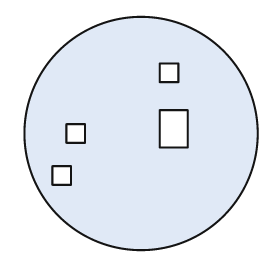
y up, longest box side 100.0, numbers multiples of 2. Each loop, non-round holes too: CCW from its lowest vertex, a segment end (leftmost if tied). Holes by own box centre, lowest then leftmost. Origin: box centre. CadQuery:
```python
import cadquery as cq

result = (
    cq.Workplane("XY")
    .moveTo(0.0, 0.0)
    .circle(50.0)
    .moveTo(-38.0, -22.0)
    .lineTo(-30.0, -22.0)
    .lineTo(-30.0, -14.0)
    .lineTo(-38.0, -14.0)
    .close()
    .moveTo(-32.0, -4.0)
    .lineTo(-24.0, -4.0)
    .lineTo(-24.0, 4.0)
    .lineTo(-32.0, 4.0)
    .close()
    .moveTo(8.0, -6.0)
    .lineTo(20.0, -6.0)
    .lineTo(20.0, 10.0)
    .lineTo(8.0, 10.0)
    .close()
    .moveTo(8.0, 22.0)
    .lineTo(16.0, 22.0)
    .lineTo(16.0, 30.0)
    .lineTo(8.0, 30.0)
    .close()
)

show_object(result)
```